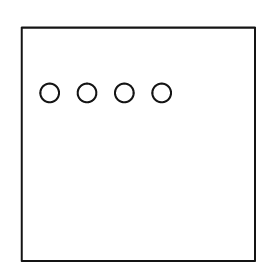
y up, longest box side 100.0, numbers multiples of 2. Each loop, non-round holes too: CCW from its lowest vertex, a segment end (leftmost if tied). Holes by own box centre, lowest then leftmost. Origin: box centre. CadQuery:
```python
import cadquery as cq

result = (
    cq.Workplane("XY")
    .moveTo(-50.0, -50.0)
    .lineTo(50.0, -50.0)
    .lineTo(50.0, 50.0)
    .lineTo(-50.0, 50.0)
    .close()
    .moveTo(-38.0, 22.0)
    .circle(4.0)
    .moveTo(-22.0, 22.0)
    .circle(4.0)
    .moveTo(-6.0, 22.0)
    .circle(4.0)
    .moveTo(10.0, 22.0)
    .circle(4.0)
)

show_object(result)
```